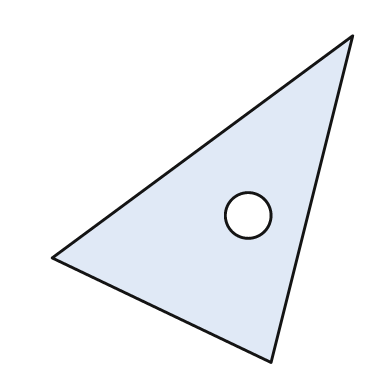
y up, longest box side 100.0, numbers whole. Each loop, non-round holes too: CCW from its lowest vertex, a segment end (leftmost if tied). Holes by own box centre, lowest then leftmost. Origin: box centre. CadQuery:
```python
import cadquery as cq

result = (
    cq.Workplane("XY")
    .moveTo(21.0, -50.0)
    .lineTo(46.0, 50.0)
    .lineTo(-46.0, -18.0)
    .close()
    .moveTo(14.0, -5.0)
    .circle(7.0)
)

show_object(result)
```